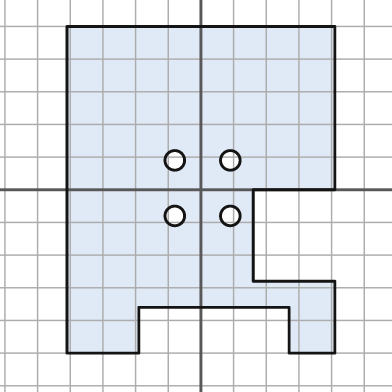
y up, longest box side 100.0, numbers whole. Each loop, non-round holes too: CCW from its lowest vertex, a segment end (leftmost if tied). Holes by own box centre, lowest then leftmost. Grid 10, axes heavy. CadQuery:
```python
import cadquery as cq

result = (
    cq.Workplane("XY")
    .moveTo(-41.0, -50.0)
    .lineTo(-19.0, -50.0)
    .lineTo(-19.0, -36.0)
    .lineTo(27.0, -36.0)
    .lineTo(27.0, -50.0)
    .lineTo(41.0, -50.0)
    .lineTo(41.0, -28.0)
    .lineTo(16.0, -28.0)
    .lineTo(16.0, 0.0)
    .lineTo(41.0, 0.0)
    .lineTo(41.0, 50.0)
    .lineTo(-41.0, 50.0)
    .close()
    .moveTo(-8.0, -8.0)
    .circle(3.0)
    .moveTo(9.0, -8.0)
    .circle(3.0)
    .moveTo(-8.0, 9.0)
    .circle(3.0)
    .moveTo(9.0, 9.0)
    .circle(3.0)
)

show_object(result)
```